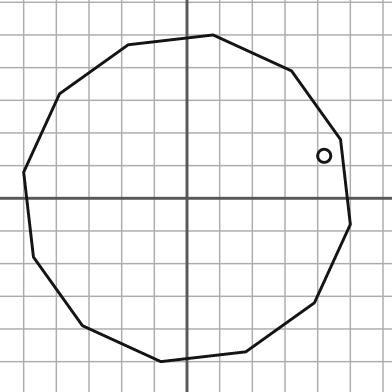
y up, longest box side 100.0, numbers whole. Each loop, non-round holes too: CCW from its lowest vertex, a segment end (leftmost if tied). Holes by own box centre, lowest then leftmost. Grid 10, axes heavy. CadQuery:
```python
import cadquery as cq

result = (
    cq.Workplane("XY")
    .moveTo(-8.0, -50.0)
    .lineTo(18.0, -47.0)
    .lineTo(39.0, -32.0)
    .lineTo(50.0, -8.0)
    .lineTo(47.0, 18.0)
    .lineTo(32.0, 39.0)
    .lineTo(8.0, 50.0)
    .lineTo(-18.0, 47.0)
    .lineTo(-39.0, 32.0)
    .lineTo(-50.0, 8.0)
    .lineTo(-47.0, -18.0)
    .lineTo(-32.0, -39.0)
    .close()
    .moveTo(42.0, 13.0)
    .circle(2.0)
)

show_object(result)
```